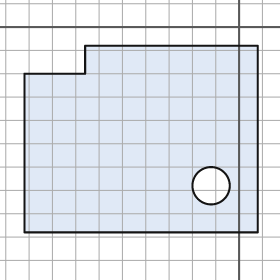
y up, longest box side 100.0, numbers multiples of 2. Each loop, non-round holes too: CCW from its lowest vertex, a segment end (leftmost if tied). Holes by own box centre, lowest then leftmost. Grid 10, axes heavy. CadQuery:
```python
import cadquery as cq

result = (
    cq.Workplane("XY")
    .moveTo(-92.0, -88.0)
    .lineTo(8.0, -88.0)
    .lineTo(8.0, -8.0)
    .lineTo(-66.0, -8.0)
    .lineTo(-66.0, -20.0)
    .lineTo(-92.0, -20.0)
    .close()
    .moveTo(-12.0, -68.0)
    .circle(8.0)
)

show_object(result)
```